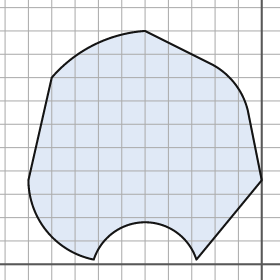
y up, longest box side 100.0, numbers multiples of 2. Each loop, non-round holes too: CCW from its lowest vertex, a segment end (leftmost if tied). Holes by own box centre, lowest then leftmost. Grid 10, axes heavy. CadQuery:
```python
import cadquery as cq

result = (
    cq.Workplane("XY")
    .moveTo(-72.0, 2.0)
    .threePointArc((-50.0, 18.0), (-28.0, 2.0))
    .lineTo(0.0, 36.0)
    .lineTo(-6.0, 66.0)
    .threePointArc((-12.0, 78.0), (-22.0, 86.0))
    .lineTo(-50.0, 100.0)
    .threePointArc((-72.0, 94.0), (-90.0, 80.0))
    .lineTo(-100.0, 36.0)
    .threePointArc((-92.0, 14.0), (-72.0, 2.0))
    .close()
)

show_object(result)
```